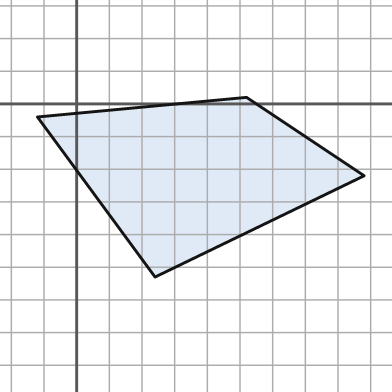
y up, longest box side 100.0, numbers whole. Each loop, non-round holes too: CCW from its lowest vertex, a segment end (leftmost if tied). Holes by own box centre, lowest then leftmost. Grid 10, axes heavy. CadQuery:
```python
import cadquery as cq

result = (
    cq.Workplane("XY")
    .moveTo(24.0, -53.0)
    .lineTo(88.0, -22.0)
    .lineTo(52.0, 2.0)
    .lineTo(-12.0, -4.0)
    .close()
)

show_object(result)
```